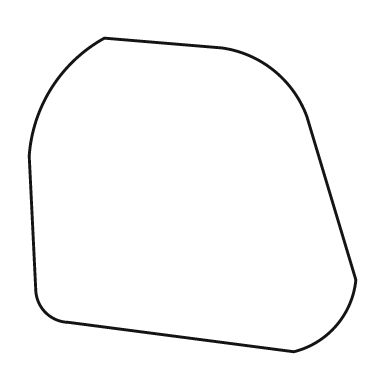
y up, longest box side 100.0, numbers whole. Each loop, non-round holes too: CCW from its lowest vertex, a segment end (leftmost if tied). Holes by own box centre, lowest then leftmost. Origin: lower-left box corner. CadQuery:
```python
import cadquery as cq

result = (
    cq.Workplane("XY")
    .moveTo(81.0, 0.0)
    .threePointArc((94.0, 8.0), (100.0, 22.0))
    .lineTo(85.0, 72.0)
    .threePointArc((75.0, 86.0), (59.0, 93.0))
    .lineTo(23.0, 96.0)
    .threePointArc((7.0, 81.0), (0.0, 60.0))
    .lineTo(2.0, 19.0)
    .threePointArc((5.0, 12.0), (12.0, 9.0))
    .close()
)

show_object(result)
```